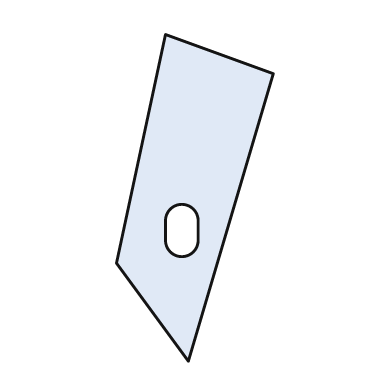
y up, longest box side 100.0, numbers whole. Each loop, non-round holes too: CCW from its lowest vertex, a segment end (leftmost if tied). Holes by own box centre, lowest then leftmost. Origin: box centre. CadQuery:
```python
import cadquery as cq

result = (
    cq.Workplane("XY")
    .moveTo(-2.0, -50.0)
    .lineTo(24.0, 38.0)
    .lineTo(-9.0, 50.0)
    .lineTo(-24.0, -20.0)
    .close()
    .moveTo(-9.0, -13.0)
    .threePointArc((-4.0, -18.0), (1.0, -13.0))
    .lineTo(1.0, -7.0)
    .threePointArc((-4.0, -2.0), (-9.0, -7.0))
    .close()
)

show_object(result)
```